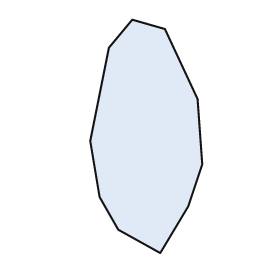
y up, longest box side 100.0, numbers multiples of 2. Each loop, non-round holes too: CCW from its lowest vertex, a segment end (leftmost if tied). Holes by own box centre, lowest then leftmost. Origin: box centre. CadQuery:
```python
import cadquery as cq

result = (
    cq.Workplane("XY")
    .moveTo(6.0, -50.0)
    .lineTo(18.0, -30.0)
    .lineTo(24.0, -12.0)
    .lineTo(22.0, 16.0)
    .lineTo(8.0, 46.0)
    .lineTo(-6.0, 50.0)
    .lineTo(-16.0, 38.0)
    .lineTo(-24.0, -2.0)
    .lineTo(-20.0, -26.0)
    .lineTo(-12.0, -40.0)
    .close()
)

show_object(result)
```